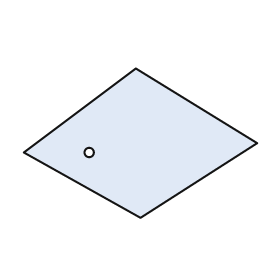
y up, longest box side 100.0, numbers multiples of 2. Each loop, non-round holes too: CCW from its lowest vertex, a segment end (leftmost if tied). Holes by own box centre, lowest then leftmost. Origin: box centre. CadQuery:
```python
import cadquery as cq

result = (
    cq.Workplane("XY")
    .moveTo(0.0, -32.0)
    .lineTo(50.0, 0.0)
    .lineTo(-2.0, 32.0)
    .lineTo(-50.0, -4.0)
    .close()
    .moveTo(-22.0, -4.0)
    .circle(2.0)
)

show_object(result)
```